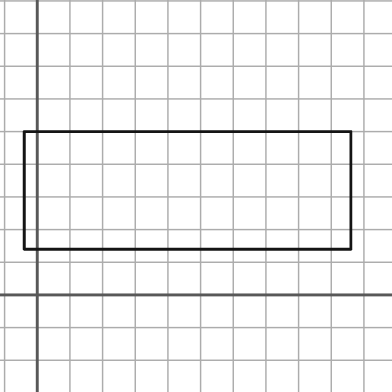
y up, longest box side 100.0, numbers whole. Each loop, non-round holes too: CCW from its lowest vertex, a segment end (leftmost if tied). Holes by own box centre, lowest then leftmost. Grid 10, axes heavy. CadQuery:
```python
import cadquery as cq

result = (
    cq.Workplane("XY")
    .moveTo(-4.0, 14.0)
    .lineTo(96.0, 14.0)
    .lineTo(96.0, 50.0)
    .lineTo(-4.0, 50.0)
    .close()
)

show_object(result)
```